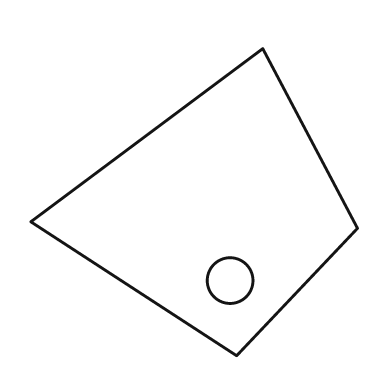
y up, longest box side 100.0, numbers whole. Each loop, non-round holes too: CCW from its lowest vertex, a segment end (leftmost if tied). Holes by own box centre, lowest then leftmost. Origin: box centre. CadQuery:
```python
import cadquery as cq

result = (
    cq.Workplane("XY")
    .moveTo(13.0, -47.0)
    .lineTo(50.0, -8.0)
    .lineTo(21.0, 47.0)
    .lineTo(-50.0, -6.0)
    .close()
    .moveTo(11.0, -24.0)
    .circle(7.0)
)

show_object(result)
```